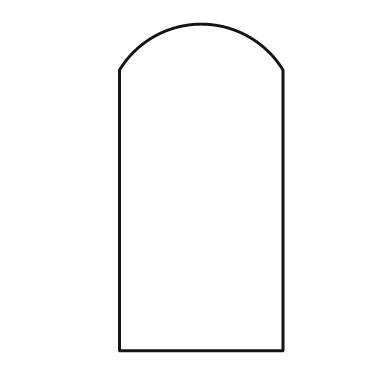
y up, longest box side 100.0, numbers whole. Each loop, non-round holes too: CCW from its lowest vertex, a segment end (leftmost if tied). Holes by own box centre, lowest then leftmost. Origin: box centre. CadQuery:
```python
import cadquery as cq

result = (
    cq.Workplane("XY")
    .moveTo(-25.0, -50.0)
    .lineTo(25.0, -50.0)
    .lineTo(25.0, 36.0)
    .threePointArc((0.0, 50.0), (-25.0, 36.0))
    .close()
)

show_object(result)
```